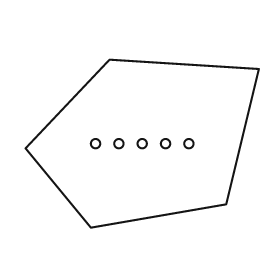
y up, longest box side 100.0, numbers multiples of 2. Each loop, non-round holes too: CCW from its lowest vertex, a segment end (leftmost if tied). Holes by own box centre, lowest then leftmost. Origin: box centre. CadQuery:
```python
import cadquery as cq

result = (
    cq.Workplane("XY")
    .moveTo(-22.0, -36.0)
    .lineTo(36.0, -26.0)
    .lineTo(50.0, 32.0)
    .lineTo(-14.0, 36.0)
    .lineTo(-50.0, -2.0)
    .close()
    .moveTo(-20.0, 0.0)
    .circle(2.0)
    .moveTo(-10.0, 0.0)
    .circle(2.0)
    .moveTo(0.0, 0.0)
    .circle(2.0)
    .moveTo(10.0, 0.0)
    .circle(2.0)
    .moveTo(20.0, 0.0)
    .circle(2.0)
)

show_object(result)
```